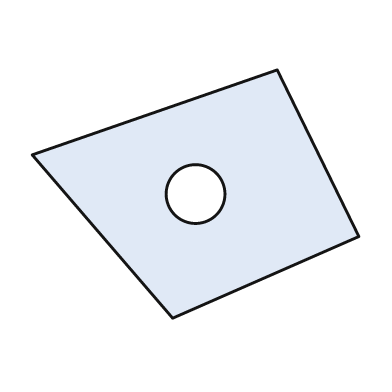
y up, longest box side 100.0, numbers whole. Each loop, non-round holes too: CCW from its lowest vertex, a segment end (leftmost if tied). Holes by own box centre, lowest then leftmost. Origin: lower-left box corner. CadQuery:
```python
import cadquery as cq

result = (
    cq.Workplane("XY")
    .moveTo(43.0, 0.0)
    .lineTo(100.0, 25.0)
    .lineTo(75.0, 76.0)
    .lineTo(0.0, 50.0)
    .close()
    .moveTo(50.0, 38.0)
    .circle(9.0)
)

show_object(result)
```